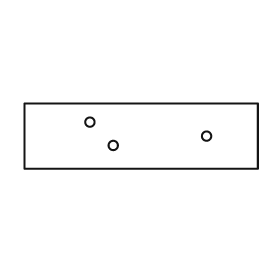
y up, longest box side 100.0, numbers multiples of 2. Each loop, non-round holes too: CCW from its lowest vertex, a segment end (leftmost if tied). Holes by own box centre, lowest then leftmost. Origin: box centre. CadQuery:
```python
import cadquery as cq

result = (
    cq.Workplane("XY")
    .moveTo(-50.0, -14.0)
    .lineTo(50.0, -14.0)
    .lineTo(50.0, 14.0)
    .lineTo(-50.0, 14.0)
    .close()
    .moveTo(-12.0, -4.0)
    .circle(2.0)
    .moveTo(28.0, 0.0)
    .circle(2.0)
    .moveTo(-22.0, 6.0)
    .circle(2.0)
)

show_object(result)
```